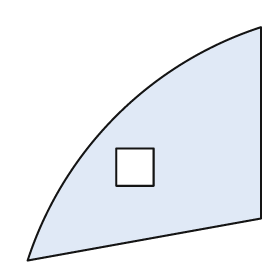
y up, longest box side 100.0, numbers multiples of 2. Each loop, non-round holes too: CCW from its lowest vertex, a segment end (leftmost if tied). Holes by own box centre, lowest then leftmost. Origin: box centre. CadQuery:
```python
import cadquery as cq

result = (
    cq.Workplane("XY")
    .moveTo(-50.0, -50.0)
    .lineTo(50.0, -32.0)
    .lineTo(50.0, 50.0)
    .threePointArc((-12.0, 12.0), (-50.0, -50.0))
    .close()
    .moveTo(-12.0, -18.0)
    .lineTo(4.0, -18.0)
    .lineTo(4.0, -2.0)
    .lineTo(-12.0, -2.0)
    .close()
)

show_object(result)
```